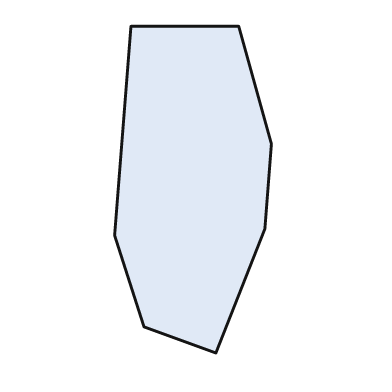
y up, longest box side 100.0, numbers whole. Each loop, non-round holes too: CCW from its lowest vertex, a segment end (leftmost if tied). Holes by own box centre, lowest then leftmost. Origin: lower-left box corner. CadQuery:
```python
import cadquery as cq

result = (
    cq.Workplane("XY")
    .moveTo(31.0, 0.0)
    .lineTo(46.0, 38.0)
    .lineTo(48.0, 64.0)
    .lineTo(38.0, 100.0)
    .lineTo(5.0, 100.0)
    .lineTo(0.0, 36.0)
    .lineTo(9.0, 8.0)
    .close()
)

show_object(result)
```